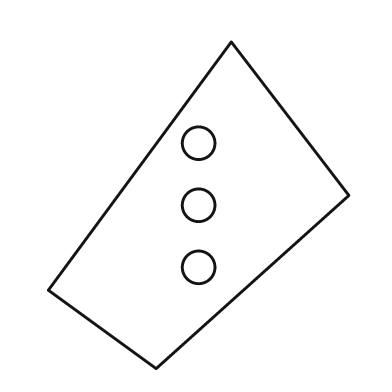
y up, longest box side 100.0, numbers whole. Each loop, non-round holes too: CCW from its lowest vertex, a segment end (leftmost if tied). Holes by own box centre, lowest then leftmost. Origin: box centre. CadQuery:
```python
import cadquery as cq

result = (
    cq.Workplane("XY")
    .moveTo(-13.0, -50.0)
    .lineTo(46.0, 3.0)
    .lineTo(10.0, 50.0)
    .lineTo(-46.0, -26.0)
    .close()
    .moveTo(0.0, -19.0)
    .circle(5.0)
    .moveTo(0.0, 0.0)
    .circle(5.0)
    .moveTo(0.0, 19.0)
    .circle(5.0)
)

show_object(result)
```